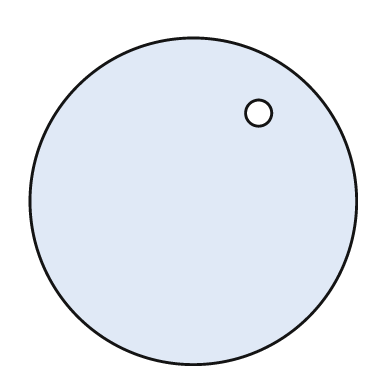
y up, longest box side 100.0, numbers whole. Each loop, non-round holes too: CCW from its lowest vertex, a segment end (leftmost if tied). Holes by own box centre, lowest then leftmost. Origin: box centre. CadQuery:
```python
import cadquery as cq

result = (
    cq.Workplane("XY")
    .moveTo(0.0, 0.0)
    .circle(50.0)
    .moveTo(20.0, 27.0)
    .circle(4.0)
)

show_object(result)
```